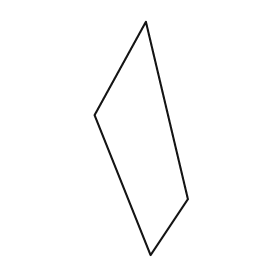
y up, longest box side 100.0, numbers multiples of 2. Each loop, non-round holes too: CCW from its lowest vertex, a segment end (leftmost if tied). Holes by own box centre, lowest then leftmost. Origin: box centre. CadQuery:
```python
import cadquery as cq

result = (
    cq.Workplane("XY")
    .moveTo(4.0, -50.0)
    .lineTo(20.0, -26.0)
    .lineTo(2.0, 50.0)
    .lineTo(-20.0, 10.0)
    .close()
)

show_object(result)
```